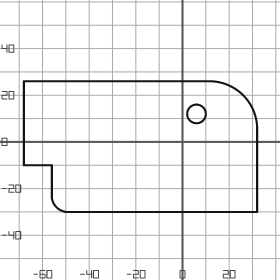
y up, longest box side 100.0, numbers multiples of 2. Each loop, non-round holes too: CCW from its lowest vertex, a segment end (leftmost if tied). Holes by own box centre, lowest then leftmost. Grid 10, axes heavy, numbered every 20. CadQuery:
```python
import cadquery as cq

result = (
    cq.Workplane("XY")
    .moveTo(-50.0, -30.0)
    .lineTo(32.0, -30.0)
    .lineTo(32.0, 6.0)
    .threePointArc((26.0, 20.0), (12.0, 26.0))
    .lineTo(-68.0, 26.0)
    .lineTo(-68.0, -10.0)
    .lineTo(-56.0, -10.0)
    .lineTo(-56.0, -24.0)
    .threePointArc((-54.0, -28.0), (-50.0, -30.0))
    .close()
    .moveTo(6.0, 12.0)
    .circle(4.0)
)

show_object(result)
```